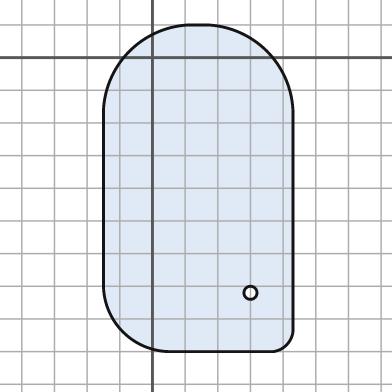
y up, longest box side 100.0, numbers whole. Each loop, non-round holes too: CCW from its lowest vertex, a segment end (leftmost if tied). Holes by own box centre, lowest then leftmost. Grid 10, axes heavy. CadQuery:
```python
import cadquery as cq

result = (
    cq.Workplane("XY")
    .moveTo(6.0, -90.0)
    .lineTo(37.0, -90.0)
    .threePointArc((41.0, -88.0), (43.0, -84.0))
    .lineTo(43.0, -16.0)
    .threePointArc((35.0, 2.0), (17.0, 10.0))
    .lineTo(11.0, 10.0)
    .threePointArc((-7.0, 2.0), (-15.0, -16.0))
    .lineTo(-15.0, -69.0)
    .threePointArc((-9.0, -84.0), (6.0, -90.0))
    .close()
    .moveTo(30.0, -72.0)
    .circle(2.0)
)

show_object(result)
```